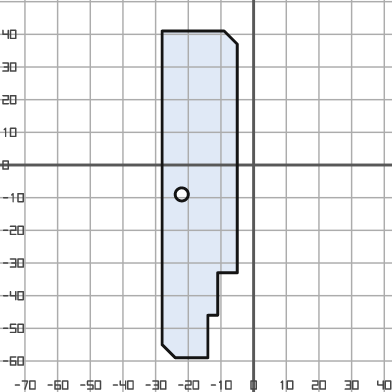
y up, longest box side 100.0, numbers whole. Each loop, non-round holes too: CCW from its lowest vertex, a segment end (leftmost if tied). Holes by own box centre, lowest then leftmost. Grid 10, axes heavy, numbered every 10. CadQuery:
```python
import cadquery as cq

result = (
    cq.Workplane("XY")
    .moveTo(-24.0, -59.0)
    .lineTo(-14.0, -59.0)
    .lineTo(-14.0, -46.0)
    .lineTo(-11.0, -46.0)
    .lineTo(-11.0, -33.0)
    .lineTo(-5.0, -33.0)
    .lineTo(-5.0, 37.0)
    .lineTo(-9.0, 41.0)
    .lineTo(-28.0, 41.0)
    .lineTo(-28.0, -55.0)
    .close()
    .moveTo(-22.0, -9.0)
    .circle(2.0)
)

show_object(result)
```